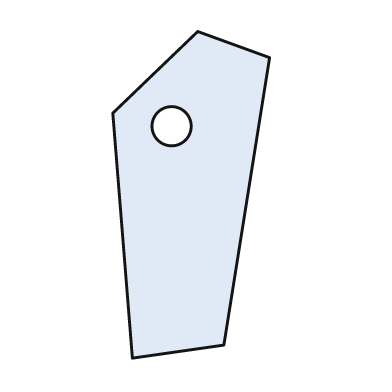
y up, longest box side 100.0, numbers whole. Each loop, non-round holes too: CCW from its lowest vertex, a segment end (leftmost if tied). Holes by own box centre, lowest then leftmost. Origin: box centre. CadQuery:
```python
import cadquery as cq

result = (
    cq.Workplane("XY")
    .moveTo(-18.0, -50.0)
    .lineTo(10.0, -46.0)
    .lineTo(24.0, 42.0)
    .lineTo(2.0, 50.0)
    .lineTo(-24.0, 25.0)
    .close()
    .moveTo(-6.0, 21.0)
    .circle(6.0)
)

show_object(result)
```